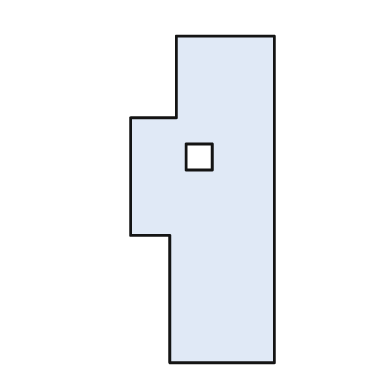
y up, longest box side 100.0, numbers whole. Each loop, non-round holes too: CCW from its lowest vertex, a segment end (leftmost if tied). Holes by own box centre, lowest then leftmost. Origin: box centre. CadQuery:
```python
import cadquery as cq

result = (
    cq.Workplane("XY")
    .moveTo(-10.0, -50.0)
    .lineTo(22.0, -50.0)
    .lineTo(22.0, 50.0)
    .lineTo(-8.0, 50.0)
    .lineTo(-8.0, 25.0)
    .lineTo(-22.0, 25.0)
    .lineTo(-22.0, -11.0)
    .lineTo(-10.0, -11.0)
    .close()
    .moveTo(-5.0, 9.0)
    .lineTo(3.0, 9.0)
    .lineTo(3.0, 17.0)
    .lineTo(-5.0, 17.0)
    .close()
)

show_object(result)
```